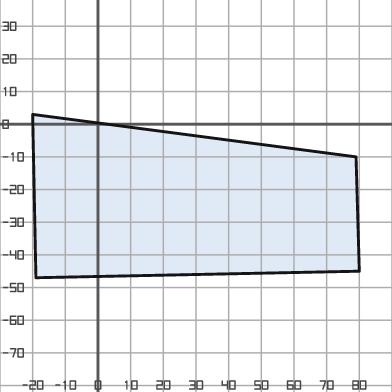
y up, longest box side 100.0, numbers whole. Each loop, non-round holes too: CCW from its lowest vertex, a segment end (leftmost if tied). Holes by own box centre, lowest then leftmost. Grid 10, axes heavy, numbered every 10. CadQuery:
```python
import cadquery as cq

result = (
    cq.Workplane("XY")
    .moveTo(-19.0, -47.0)
    .lineTo(80.0, -45.0)
    .lineTo(79.0, -10.0)
    .lineTo(-20.0, 3.0)
    .close()
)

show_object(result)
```